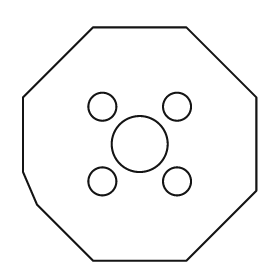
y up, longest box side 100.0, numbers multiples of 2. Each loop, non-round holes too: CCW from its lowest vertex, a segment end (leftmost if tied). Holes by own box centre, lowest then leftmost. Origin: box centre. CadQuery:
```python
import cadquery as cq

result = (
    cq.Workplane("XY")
    .moveTo(-20.0, -50.0)
    .lineTo(20.0, -50.0)
    .lineTo(50.0, -20.0)
    .lineTo(50.0, 20.0)
    .lineTo(20.0, 50.0)
    .lineTo(-20.0, 50.0)
    .lineTo(-50.0, 20.0)
    .lineTo(-50.0, -12.0)
    .lineTo(-44.0, -26.0)
    .close()
    .moveTo(-16.0, -16.0)
    .circle(6.0)
    .moveTo(16.0, -16.0)
    .circle(6.0)
    .moveTo(0.0, 0.0)
    .circle(12.0)
    .moveTo(-16.0, 16.0)
    .circle(6.0)
    .moveTo(16.0, 16.0)
    .circle(6.0)
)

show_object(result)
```